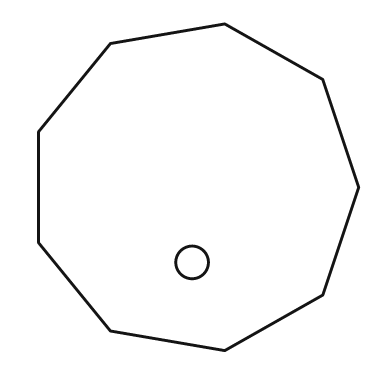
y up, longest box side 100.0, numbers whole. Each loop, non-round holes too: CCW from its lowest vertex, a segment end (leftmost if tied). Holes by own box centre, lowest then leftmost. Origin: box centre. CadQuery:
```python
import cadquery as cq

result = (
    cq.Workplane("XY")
    .moveTo(8.0, -50.0)
    .lineTo(38.0, -33.0)
    .lineTo(49.0, 0.0)
    .lineTo(38.0, 33.0)
    .lineTo(8.0, 50.0)
    .lineTo(-27.0, 44.0)
    .lineTo(-49.0, 17.0)
    .lineTo(-49.0, -17.0)
    .lineTo(-27.0, -44.0)
    .close()
    .moveTo(-2.0, -23.0)
    .circle(5.0)
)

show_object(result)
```